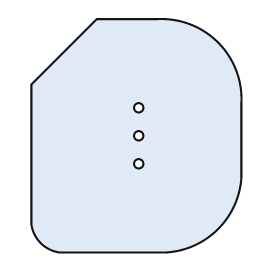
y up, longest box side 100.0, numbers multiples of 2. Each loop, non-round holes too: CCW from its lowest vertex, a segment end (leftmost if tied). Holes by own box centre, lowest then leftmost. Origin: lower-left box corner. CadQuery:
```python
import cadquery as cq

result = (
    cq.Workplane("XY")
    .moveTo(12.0, 0.0)
    .lineTo(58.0, 0.0)
    .threePointArc((80.0, 10.0), (90.0, 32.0))
    .lineTo(90.0, 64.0)
    .threePointArc((80.0, 90.0), (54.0, 100.0))
    .lineTo(28.0, 100.0)
    .lineTo(0.0, 72.0)
    .lineTo(0.0, 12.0)
    .threePointArc((4.0, 4.0), (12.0, 0.0))
    .close()
    .moveTo(46.0, 38.0)
    .circle(2.0)
    .moveTo(46.0, 50.0)
    .circle(2.0)
    .moveTo(46.0, 62.0)
    .circle(2.0)
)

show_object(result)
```